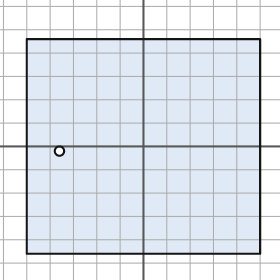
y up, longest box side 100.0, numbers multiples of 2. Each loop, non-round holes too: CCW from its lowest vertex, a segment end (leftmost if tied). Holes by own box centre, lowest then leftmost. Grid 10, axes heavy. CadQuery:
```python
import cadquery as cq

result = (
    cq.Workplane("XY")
    .moveTo(-50.0, -46.0)
    .lineTo(50.0, -46.0)
    .lineTo(50.0, 46.0)
    .lineTo(-50.0, 46.0)
    .close()
    .moveTo(-36.0, -2.0)
    .circle(2.0)
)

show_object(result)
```